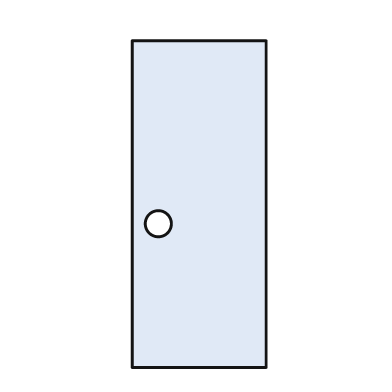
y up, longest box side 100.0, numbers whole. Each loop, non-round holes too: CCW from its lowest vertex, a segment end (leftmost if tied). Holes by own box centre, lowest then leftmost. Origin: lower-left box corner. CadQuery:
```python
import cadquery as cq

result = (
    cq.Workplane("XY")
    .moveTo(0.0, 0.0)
    .lineTo(41.0, 0.0)
    .lineTo(41.0, 100.0)
    .lineTo(0.0, 100.0)
    .close()
    .moveTo(8.0, 44.0)
    .circle(4.0)
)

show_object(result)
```